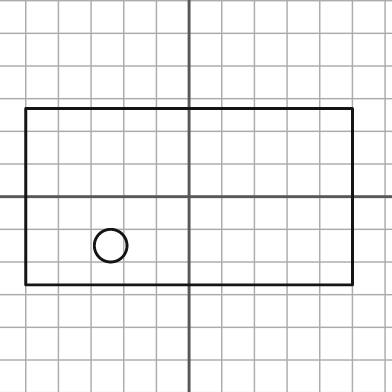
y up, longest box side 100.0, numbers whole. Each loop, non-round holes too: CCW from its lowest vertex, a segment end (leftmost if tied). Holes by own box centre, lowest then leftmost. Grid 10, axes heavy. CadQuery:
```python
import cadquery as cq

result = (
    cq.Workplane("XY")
    .moveTo(-50.0, -27.0)
    .lineTo(50.0, -27.0)
    .lineTo(50.0, 27.0)
    .lineTo(-50.0, 27.0)
    .close()
    .moveTo(-24.0, -15.0)
    .circle(5.0)
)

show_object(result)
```